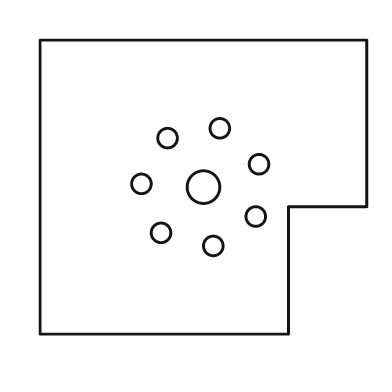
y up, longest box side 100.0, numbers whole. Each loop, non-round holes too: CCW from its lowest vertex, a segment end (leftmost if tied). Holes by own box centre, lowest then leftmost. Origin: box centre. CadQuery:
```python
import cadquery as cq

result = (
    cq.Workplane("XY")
    .moveTo(-50.0, -45.0)
    .lineTo(26.0, -45.0)
    .lineTo(26.0, -6.0)
    .lineTo(50.0, -6.0)
    .lineTo(50.0, 45.0)
    .lineTo(-50.0, 45.0)
    .close()
    .moveTo(3.0, -18.0)
    .circle(3.0)
    .moveTo(-13.0, -14.0)
    .circle(3.0)
    .moveTo(16.0, -9.0)
    .circle(3.0)
    .moveTo(0.0, 0.0)
    .circle(5.0)
    .moveTo(-19.0, 1.0)
    .circle(3.0)
    .moveTo(17.0, 7.0)
    .circle(3.0)
    .moveTo(-11.0, 15.0)
    .circle(3.0)
    .moveTo(5.0, 18.0)
    .circle(3.0)
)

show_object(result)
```